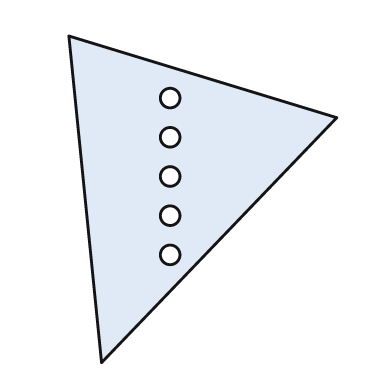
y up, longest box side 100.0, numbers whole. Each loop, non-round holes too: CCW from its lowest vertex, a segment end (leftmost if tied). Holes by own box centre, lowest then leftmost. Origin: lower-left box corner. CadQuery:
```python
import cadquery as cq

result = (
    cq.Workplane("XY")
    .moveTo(10.0, 0.0)
    .lineTo(82.0, 75.0)
    .lineTo(0.0, 100.0)
    .close()
    .moveTo(31.0, 33.0)
    .circle(3.0)
    .moveTo(31.0, 45.0)
    .circle(3.0)
    .moveTo(31.0, 57.0)
    .circle(3.0)
    .moveTo(31.0, 69.0)
    .circle(3.0)
    .moveTo(31.0, 81.0)
    .circle(3.0)
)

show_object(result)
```